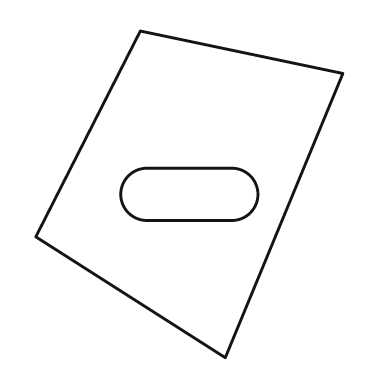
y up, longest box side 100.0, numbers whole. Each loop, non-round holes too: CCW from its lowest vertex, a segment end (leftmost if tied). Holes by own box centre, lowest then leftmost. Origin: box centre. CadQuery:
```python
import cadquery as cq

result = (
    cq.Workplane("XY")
    .moveTo(11.0, -50.0)
    .lineTo(47.0, 37.0)
    .lineTo(-15.0, 50.0)
    .lineTo(-47.0, -13.0)
    .close()
    .moveTo(-13.0, -8.0)
    .lineTo(13.0, -8.0)
    .threePointArc((21.0, 0.0), (13.0, 8.0))
    .lineTo(-13.0, 8.0)
    .threePointArc((-21.0, 0.0), (-13.0, -8.0))
    .close()
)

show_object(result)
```